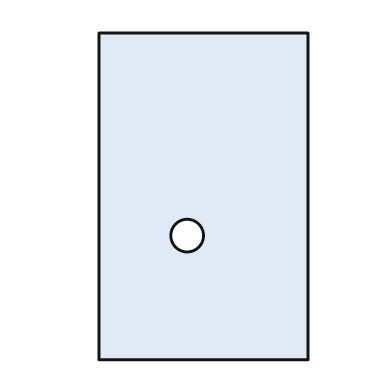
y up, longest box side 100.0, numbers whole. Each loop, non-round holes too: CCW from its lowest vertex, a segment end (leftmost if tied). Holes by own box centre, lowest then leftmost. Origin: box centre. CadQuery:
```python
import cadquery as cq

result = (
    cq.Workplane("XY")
    .moveTo(-32.0, -50.0)
    .lineTo(32.0, -50.0)
    .lineTo(32.0, 50.0)
    .lineTo(-32.0, 50.0)
    .close()
    .moveTo(-5.0, -12.0)
    .circle(5.0)
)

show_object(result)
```